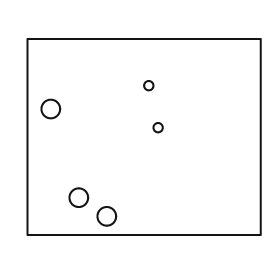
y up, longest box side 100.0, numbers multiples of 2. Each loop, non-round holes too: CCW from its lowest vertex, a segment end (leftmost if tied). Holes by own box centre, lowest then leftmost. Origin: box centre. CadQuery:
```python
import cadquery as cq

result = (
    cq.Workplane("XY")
    .moveTo(-50.0, -42.0)
    .lineTo(50.0, -42.0)
    .lineTo(50.0, 42.0)
    .lineTo(-50.0, 42.0)
    .close()
    .moveTo(-16.0, -34.0)
    .circle(4.0)
    .moveTo(-28.0, -26.0)
    .circle(4.0)
    .moveTo(6.0, 4.0)
    .circle(2.0)
    .moveTo(-40.0, 12.0)
    .circle(4.0)
    .moveTo(2.0, 22.0)
    .circle(2.0)
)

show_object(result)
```